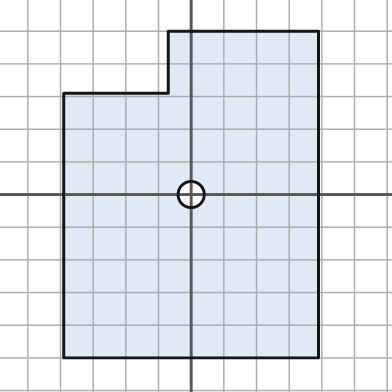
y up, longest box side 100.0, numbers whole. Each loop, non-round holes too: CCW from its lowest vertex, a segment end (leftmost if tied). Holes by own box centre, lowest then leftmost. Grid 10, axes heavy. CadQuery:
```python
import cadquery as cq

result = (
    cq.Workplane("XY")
    .moveTo(-39.0, -50.0)
    .lineTo(39.0, -50.0)
    .lineTo(39.0, 50.0)
    .lineTo(-7.0, 50.0)
    .lineTo(-7.0, 31.0)
    .lineTo(-39.0, 31.0)
    .close()
    .moveTo(0.0, 0.0)
    .circle(4.0)
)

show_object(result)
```